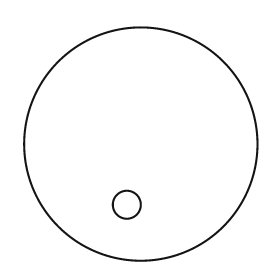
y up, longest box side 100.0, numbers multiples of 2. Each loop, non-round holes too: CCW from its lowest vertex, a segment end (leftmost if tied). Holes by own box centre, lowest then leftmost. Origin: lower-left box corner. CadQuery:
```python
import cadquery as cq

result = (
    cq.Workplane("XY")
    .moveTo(50.0, 50.0)
    .circle(50.0)
    .moveTo(44.0, 24.0)
    .circle(6.0)
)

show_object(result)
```